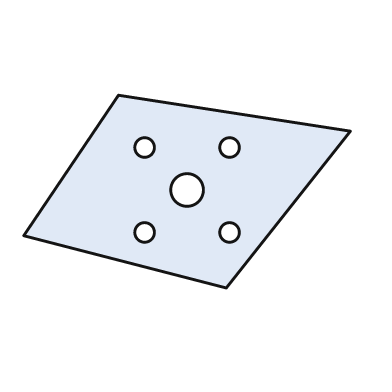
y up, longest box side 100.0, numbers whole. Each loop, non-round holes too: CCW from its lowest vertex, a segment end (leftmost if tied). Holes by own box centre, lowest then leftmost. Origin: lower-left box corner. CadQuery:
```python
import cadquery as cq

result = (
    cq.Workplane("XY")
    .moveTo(62.0, 0.0)
    .lineTo(100.0, 48.0)
    .lineTo(29.0, 59.0)
    .lineTo(0.0, 16.0)
    .close()
    .moveTo(37.0, 17.0)
    .circle(3.0)
    .moveTo(63.0, 17.0)
    .circle(3.0)
    .moveTo(50.0, 30.0)
    .circle(5.0)
    .moveTo(37.0, 43.0)
    .circle(3.0)
    .moveTo(63.0, 43.0)
    .circle(3.0)
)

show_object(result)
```